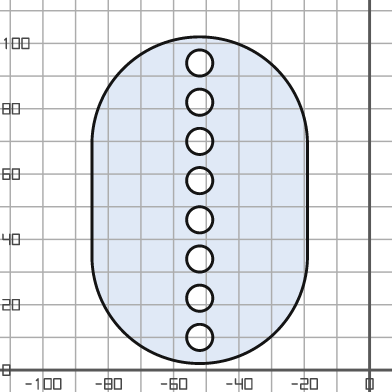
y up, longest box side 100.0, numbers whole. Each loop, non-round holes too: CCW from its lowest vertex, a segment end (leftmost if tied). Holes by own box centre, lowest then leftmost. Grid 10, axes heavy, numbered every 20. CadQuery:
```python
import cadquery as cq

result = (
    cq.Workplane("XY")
    .moveTo(-85.0, 35.0)
    .threePointArc((-52.0, 2.0), (-19.0, 35.0))
    .lineTo(-19.0, 69.0)
    .threePointArc((-52.0, 102.0), (-85.0, 69.0))
    .close()
    .moveTo(-52.0, 10.0)
    .circle(4.0)
    .moveTo(-52.0, 22.0)
    .circle(4.0)
    .moveTo(-52.0, 34.0)
    .circle(4.0)
    .moveTo(-52.0, 46.0)
    .circle(4.0)
    .moveTo(-52.0, 58.0)
    .circle(4.0)
    .moveTo(-52.0, 70.0)
    .circle(4.0)
    .moveTo(-52.0, 82.0)
    .circle(4.0)
    .moveTo(-52.0, 94.0)
    .circle(4.0)
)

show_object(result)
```